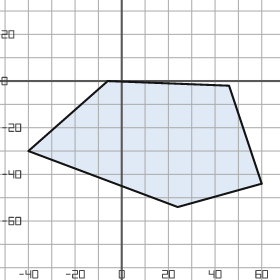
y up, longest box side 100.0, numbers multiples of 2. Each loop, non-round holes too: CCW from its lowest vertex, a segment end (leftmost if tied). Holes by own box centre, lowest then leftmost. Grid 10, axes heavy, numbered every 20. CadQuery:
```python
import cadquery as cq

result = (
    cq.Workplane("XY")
    .moveTo(24.0, -54.0)
    .lineTo(60.0, -44.0)
    .lineTo(46.0, -2.0)
    .lineTo(-6.0, 0.0)
    .lineTo(-40.0, -30.0)
    .close()
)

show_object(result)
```